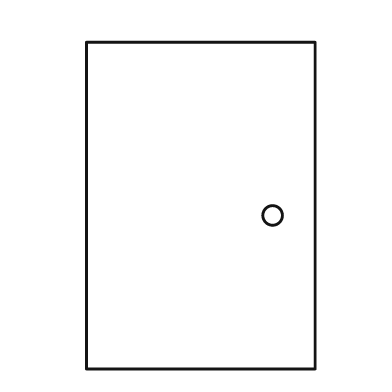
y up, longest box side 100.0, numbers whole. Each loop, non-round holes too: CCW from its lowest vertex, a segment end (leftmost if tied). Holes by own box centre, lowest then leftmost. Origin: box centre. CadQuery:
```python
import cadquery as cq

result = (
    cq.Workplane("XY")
    .moveTo(-35.0, -50.0)
    .lineTo(35.0, -50.0)
    .lineTo(35.0, 50.0)
    .lineTo(-35.0, 50.0)
    .close()
    .moveTo(22.0, -3.0)
    .circle(3.0)
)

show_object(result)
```